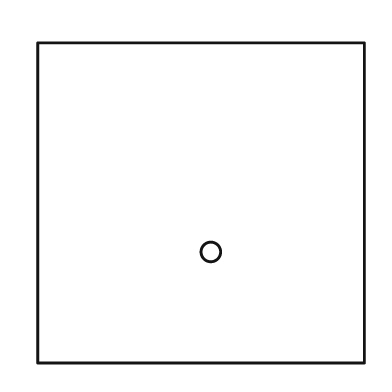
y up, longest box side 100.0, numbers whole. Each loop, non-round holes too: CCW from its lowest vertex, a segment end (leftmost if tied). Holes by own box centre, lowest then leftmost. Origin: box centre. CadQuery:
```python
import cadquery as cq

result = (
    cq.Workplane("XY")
    .moveTo(-50.0, -49.0)
    .lineTo(50.0, -49.0)
    .lineTo(50.0, 49.0)
    .lineTo(-50.0, 49.0)
    .close()
    .moveTo(3.0, -15.0)
    .circle(3.0)
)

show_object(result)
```